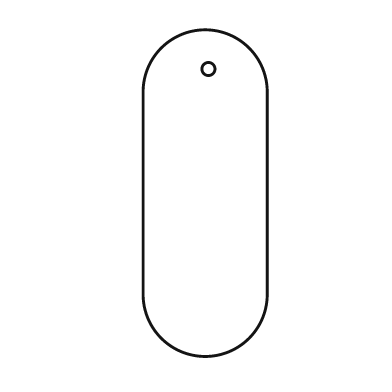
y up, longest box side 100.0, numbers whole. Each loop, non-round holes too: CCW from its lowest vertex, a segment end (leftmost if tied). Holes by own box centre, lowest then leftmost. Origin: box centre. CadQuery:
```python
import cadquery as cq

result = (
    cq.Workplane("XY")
    .moveTo(-19.0, -31.0)
    .threePointArc((0.0, -50.0), (19.0, -31.0))
    .lineTo(19.0, 31.0)
    .threePointArc((0.0, 50.0), (-19.0, 31.0))
    .close()
    .moveTo(1.0, 38.0)
    .circle(2.0)
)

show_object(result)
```